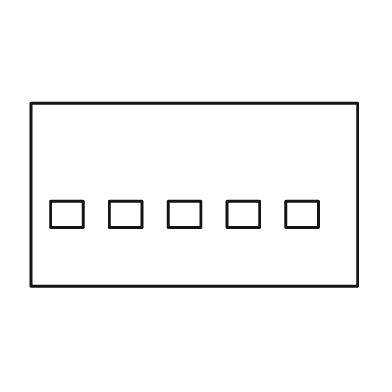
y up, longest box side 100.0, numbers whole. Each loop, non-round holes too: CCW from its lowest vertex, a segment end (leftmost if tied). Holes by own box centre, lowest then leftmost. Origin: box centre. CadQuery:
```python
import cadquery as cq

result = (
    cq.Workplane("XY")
    .moveTo(-50.0, -28.0)
    .lineTo(50.0, -28.0)
    .lineTo(50.0, 28.0)
    .lineTo(-50.0, 28.0)
    .close()
    .moveTo(-44.0, -10.0)
    .lineTo(-34.0, -10.0)
    .lineTo(-34.0, -2.0)
    .lineTo(-44.0, -2.0)
    .close()
    .moveTo(-26.0, -10.0)
    .lineTo(-16.0, -10.0)
    .lineTo(-16.0, -2.0)
    .lineTo(-26.0, -2.0)
    .close()
    .moveTo(-8.0, -10.0)
    .lineTo(2.0, -10.0)
    .lineTo(2.0, -2.0)
    .lineTo(-8.0, -2.0)
    .close()
    .moveTo(10.0, -10.0)
    .lineTo(20.0, -10.0)
    .lineTo(20.0, -2.0)
    .lineTo(10.0, -2.0)
    .close()
    .moveTo(28.0, -10.0)
    .lineTo(38.0, -10.0)
    .lineTo(38.0, -2.0)
    .lineTo(28.0, -2.0)
    .close()
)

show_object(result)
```